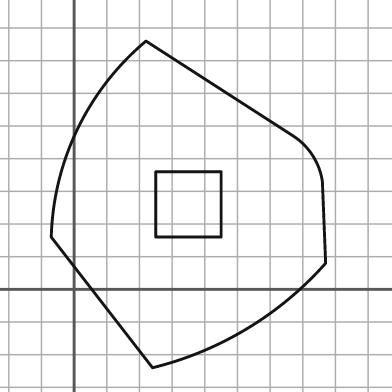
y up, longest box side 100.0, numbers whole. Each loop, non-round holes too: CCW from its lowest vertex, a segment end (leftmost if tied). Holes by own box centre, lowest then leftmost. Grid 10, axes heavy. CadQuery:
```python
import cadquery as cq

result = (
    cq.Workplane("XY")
    .moveTo(24.0, -24.0)
    .threePointArc((53.0, -12.0), (77.0, 8.0))
    .lineTo(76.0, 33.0)
    .threePointArc((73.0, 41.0), (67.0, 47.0))
    .lineTo(22.0, 76.0)
    .threePointArc((1.0, 49.0), (-7.0, 16.0))
    .close()
    .moveTo(25.0, 16.0)
    .lineTo(45.0, 16.0)
    .lineTo(45.0, 36.0)
    .lineTo(25.0, 36.0)
    .close()
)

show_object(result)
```